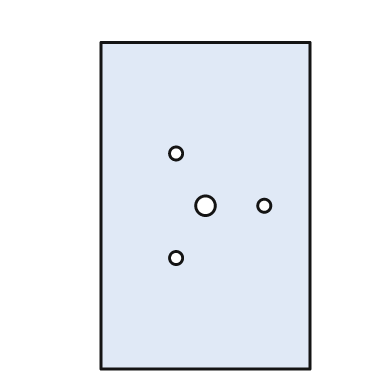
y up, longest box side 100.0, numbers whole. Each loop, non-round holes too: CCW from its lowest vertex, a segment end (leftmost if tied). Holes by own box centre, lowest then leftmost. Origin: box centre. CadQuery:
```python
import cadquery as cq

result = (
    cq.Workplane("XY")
    .moveTo(-32.0, -50.0)
    .lineTo(32.0, -50.0)
    .lineTo(32.0, 50.0)
    .lineTo(-32.0, 50.0)
    .close()
    .moveTo(-9.0, -16.0)
    .circle(2.0)
    .moveTo(0.0, 0.0)
    .circle(3.0)
    .moveTo(18.0, 0.0)
    .circle(2.0)
    .moveTo(-9.0, 16.0)
    .circle(2.0)
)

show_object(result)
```